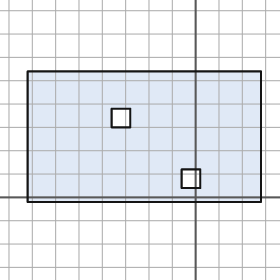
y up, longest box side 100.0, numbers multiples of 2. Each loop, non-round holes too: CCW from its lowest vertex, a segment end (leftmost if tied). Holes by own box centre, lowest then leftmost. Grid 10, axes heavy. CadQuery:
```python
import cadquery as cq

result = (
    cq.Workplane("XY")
    .moveTo(-72.0, -2.0)
    .lineTo(28.0, -2.0)
    .lineTo(28.0, 54.0)
    .lineTo(-72.0, 54.0)
    .close()
    .moveTo(-6.0, 4.0)
    .lineTo(2.0, 4.0)
    .lineTo(2.0, 12.0)
    .lineTo(-6.0, 12.0)
    .close()
    .moveTo(-36.0, 30.0)
    .lineTo(-28.0, 30.0)
    .lineTo(-28.0, 38.0)
    .lineTo(-36.0, 38.0)
    .close()
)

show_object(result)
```